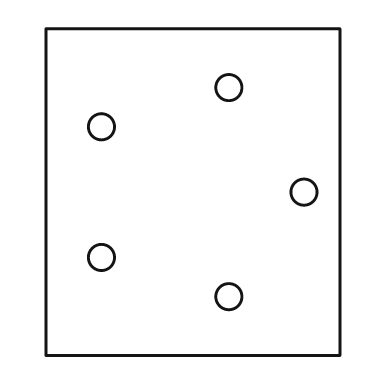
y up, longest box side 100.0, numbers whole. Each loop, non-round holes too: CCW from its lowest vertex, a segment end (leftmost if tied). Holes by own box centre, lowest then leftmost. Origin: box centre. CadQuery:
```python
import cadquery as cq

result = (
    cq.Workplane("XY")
    .moveTo(-45.0, -50.0)
    .lineTo(45.0, -50.0)
    .lineTo(45.0, 50.0)
    .lineTo(-45.0, 50.0)
    .close()
    .moveTo(11.0, -32.0)
    .circle(4.0)
    .moveTo(-28.0, -20.0)
    .circle(4.0)
    .moveTo(34.0, 0.0)
    .circle(4.0)
    .moveTo(-28.0, 20.0)
    .circle(4.0)
    .moveTo(11.0, 32.0)
    .circle(4.0)
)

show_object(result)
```